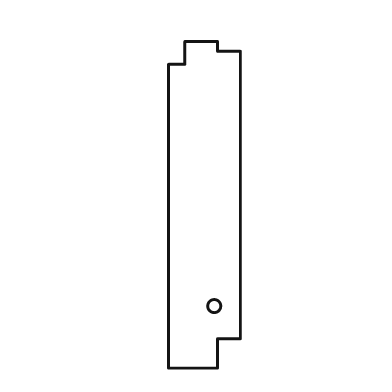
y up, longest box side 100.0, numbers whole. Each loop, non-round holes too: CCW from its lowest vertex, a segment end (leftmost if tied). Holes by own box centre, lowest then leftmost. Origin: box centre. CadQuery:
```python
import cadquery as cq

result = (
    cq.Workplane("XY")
    .moveTo(-11.0, -50.0)
    .lineTo(4.0, -50.0)
    .lineTo(4.0, -41.0)
    .lineTo(11.0, -41.0)
    .lineTo(11.0, 47.0)
    .lineTo(4.0, 47.0)
    .lineTo(4.0, 50.0)
    .lineTo(-6.0, 50.0)
    .lineTo(-6.0, 43.0)
    .lineTo(-11.0, 43.0)
    .close()
    .moveTo(3.0, -31.0)
    .circle(2.0)
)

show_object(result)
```